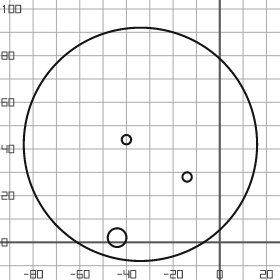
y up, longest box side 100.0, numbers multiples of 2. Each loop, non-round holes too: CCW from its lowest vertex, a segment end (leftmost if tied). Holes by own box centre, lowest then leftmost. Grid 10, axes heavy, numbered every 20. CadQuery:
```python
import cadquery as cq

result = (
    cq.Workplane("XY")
    .moveTo(-34.0, 42.0)
    .circle(50.0)
    .moveTo(-44.0, 2.0)
    .circle(4.0)
    .moveTo(-14.0, 28.0)
    .circle(2.0)
    .moveTo(-40.0, 44.0)
    .circle(2.0)
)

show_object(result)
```